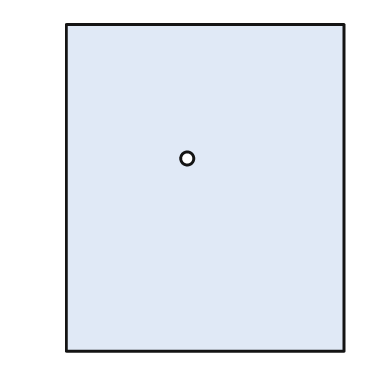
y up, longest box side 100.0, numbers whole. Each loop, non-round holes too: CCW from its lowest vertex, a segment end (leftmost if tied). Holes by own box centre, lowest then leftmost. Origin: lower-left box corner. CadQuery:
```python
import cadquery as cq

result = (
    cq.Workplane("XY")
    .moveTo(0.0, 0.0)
    .lineTo(85.0, 0.0)
    .lineTo(85.0, 100.0)
    .lineTo(0.0, 100.0)
    .close()
    .moveTo(37.0, 59.0)
    .circle(2.0)
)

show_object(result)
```